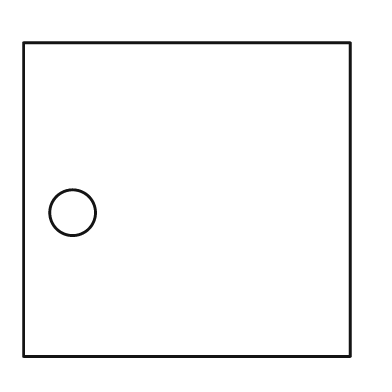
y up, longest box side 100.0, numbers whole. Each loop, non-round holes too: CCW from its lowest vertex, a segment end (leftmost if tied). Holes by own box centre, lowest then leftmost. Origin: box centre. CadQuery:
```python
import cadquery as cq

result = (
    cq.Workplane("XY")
    .moveTo(-50.0, -48.0)
    .lineTo(50.0, -48.0)
    .lineTo(50.0, 48.0)
    .lineTo(-50.0, 48.0)
    .close()
    .moveTo(-35.0, -4.0)
    .circle(7.0)
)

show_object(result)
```